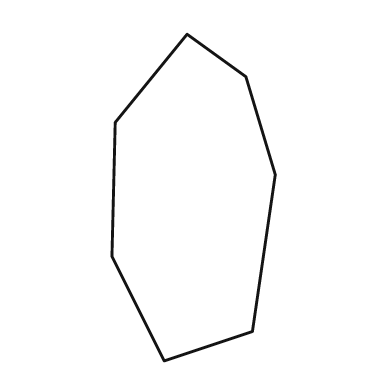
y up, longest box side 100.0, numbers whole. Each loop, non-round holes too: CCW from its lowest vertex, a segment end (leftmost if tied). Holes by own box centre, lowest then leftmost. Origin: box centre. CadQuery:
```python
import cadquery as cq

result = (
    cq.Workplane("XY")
    .moveTo(-9.0, -50.0)
    .lineTo(18.0, -41.0)
    .lineTo(25.0, 7.0)
    .lineTo(16.0, 37.0)
    .lineTo(-2.0, 50.0)
    .lineTo(-24.0, 23.0)
    .lineTo(-25.0, -18.0)
    .close()
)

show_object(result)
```